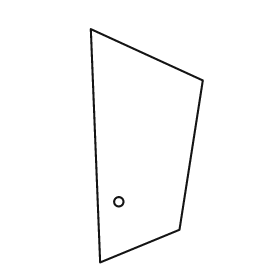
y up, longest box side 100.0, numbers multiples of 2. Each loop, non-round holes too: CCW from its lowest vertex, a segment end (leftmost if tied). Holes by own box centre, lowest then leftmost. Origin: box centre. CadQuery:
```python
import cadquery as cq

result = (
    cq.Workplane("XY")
    .moveTo(-20.0, -50.0)
    .lineTo(14.0, -36.0)
    .lineTo(24.0, 28.0)
    .lineTo(-24.0, 50.0)
    .close()
    .moveTo(-12.0, -24.0)
    .circle(2.0)
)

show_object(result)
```